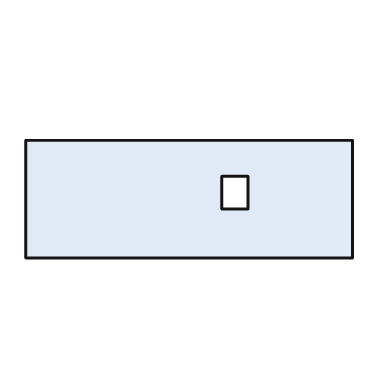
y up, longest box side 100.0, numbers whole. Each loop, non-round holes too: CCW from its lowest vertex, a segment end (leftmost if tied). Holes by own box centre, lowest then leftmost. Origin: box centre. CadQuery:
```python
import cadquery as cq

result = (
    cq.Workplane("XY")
    .moveTo(-50.0, -18.0)
    .lineTo(50.0, -18.0)
    .lineTo(50.0, 18.0)
    .lineTo(-50.0, 18.0)
    .close()
    .moveTo(10.0, -3.0)
    .lineTo(18.0, -3.0)
    .lineTo(18.0, 7.0)
    .lineTo(10.0, 7.0)
    .close()
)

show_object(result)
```